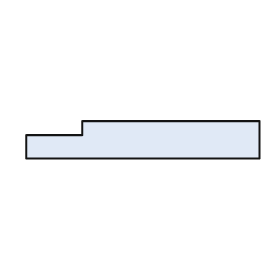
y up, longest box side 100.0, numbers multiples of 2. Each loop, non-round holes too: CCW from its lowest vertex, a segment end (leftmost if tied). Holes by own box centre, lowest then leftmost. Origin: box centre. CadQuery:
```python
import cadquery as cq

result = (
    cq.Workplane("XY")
    .moveTo(-50.0, -8.0)
    .lineTo(50.0, -8.0)
    .lineTo(50.0, 8.0)
    .lineTo(-26.0, 8.0)
    .lineTo(-26.0, 2.0)
    .lineTo(-50.0, 2.0)
    .close()
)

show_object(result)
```